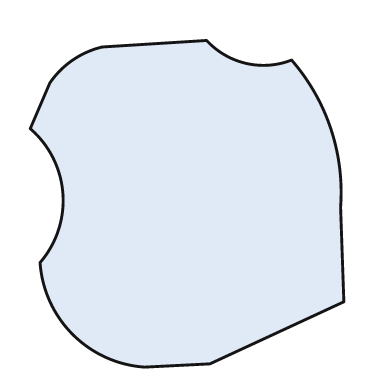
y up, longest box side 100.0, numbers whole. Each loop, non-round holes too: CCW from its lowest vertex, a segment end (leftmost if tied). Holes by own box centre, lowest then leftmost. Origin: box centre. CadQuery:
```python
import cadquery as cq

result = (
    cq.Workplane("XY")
    .moveTo(-13.0, -50.0)
    .lineTo(7.0, -49.0)
    .lineTo(48.0, -30.0)
    .lineTo(47.0, -1.0)
    .threePointArc((44.0, 23.0), (32.0, 44.0))
    .threePointArc((18.0, 43.0), (6.0, 50.0))
    .lineTo(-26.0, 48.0)
    .threePointArc((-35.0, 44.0), (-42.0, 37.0))
    .lineTo(-48.0, 23.0)
    .threePointArc((-38.0, 3.0), (-45.0, -18.0))
    .threePointArc((-35.0, -40.0), (-13.0, -50.0))
    .close()
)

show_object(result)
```